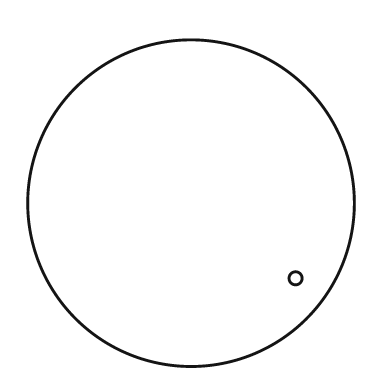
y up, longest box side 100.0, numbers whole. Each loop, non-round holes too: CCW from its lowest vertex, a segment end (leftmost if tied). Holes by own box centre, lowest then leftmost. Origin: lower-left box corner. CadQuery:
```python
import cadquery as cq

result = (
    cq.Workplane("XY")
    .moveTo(50.0, 50.0)
    .circle(50.0)
    .moveTo(82.0, 27.0)
    .circle(2.0)
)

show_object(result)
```